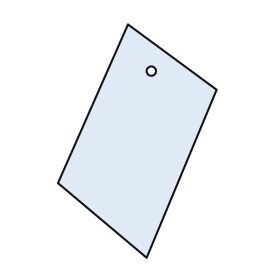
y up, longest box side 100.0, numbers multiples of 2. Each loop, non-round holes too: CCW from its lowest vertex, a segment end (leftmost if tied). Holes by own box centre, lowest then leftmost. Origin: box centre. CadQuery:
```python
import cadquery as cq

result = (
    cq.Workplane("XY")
    .moveTo(4.0, -50.0)
    .lineTo(34.0, 22.0)
    .lineTo(-4.0, 50.0)
    .lineTo(-34.0, -18.0)
    .close()
    .moveTo(6.0, 30.0)
    .circle(2.0)
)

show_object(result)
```